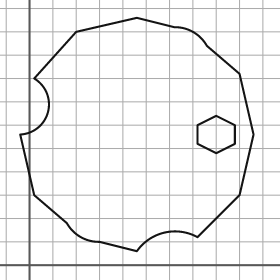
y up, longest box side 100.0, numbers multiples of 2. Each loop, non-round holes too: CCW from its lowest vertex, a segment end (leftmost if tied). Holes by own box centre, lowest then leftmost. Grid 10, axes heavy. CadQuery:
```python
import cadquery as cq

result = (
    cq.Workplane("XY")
    .moveTo(46.0, 6.0)
    .threePointArc((58.0, 14.0), (72.0, 12.0))
    .lineTo(90.0, 30.0)
    .lineTo(96.0, 56.0)
    .lineTo(90.0, 82.0)
    .lineTo(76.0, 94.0)
    .threePointArc((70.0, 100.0), (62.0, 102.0))
    .lineTo(46.0, 106.0)
    .lineTo(20.0, 100.0)
    .lineTo(2.0, 80.0)
    .threePointArc((8.0, 66.0), (-4.0, 56.0))
    .lineTo(2.0, 30.0)
    .lineTo(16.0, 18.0)
    .threePointArc((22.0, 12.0), (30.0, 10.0))
    .close()
    .moveTo(80.0, 48.0)
    .lineTo(88.0, 52.0)
    .lineTo(88.0, 60.0)
    .lineTo(80.0, 64.0)
    .lineTo(72.0, 60.0)
    .lineTo(72.0, 52.0)
    .close()
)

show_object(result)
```